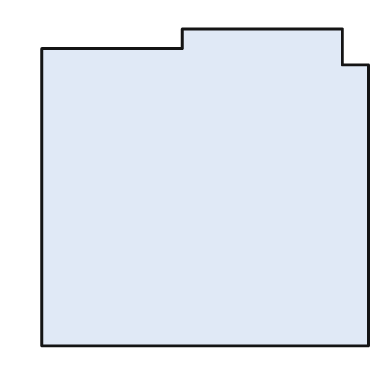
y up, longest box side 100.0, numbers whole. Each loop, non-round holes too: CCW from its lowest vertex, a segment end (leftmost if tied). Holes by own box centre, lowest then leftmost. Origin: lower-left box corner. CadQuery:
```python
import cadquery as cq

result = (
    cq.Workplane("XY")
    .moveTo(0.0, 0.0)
    .lineTo(100.0, 0.0)
    .lineTo(100.0, 86.0)
    .lineTo(92.0, 86.0)
    .lineTo(92.0, 97.0)
    .lineTo(43.0, 97.0)
    .lineTo(43.0, 91.0)
    .lineTo(0.0, 91.0)
    .close()
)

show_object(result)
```